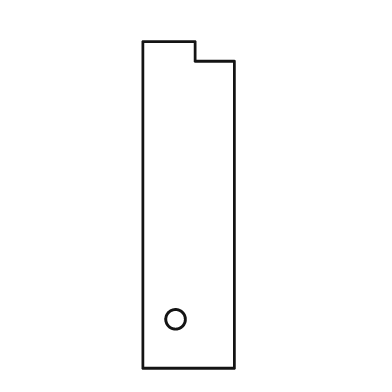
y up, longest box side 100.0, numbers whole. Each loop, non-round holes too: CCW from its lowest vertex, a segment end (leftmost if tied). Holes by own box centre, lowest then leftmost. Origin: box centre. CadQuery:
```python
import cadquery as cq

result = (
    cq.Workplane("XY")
    .moveTo(-14.0, -50.0)
    .lineTo(14.0, -50.0)
    .lineTo(14.0, 44.0)
    .lineTo(2.0, 44.0)
    .lineTo(2.0, 50.0)
    .lineTo(-14.0, 50.0)
    .close()
    .moveTo(-4.0, -35.0)
    .circle(3.0)
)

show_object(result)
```